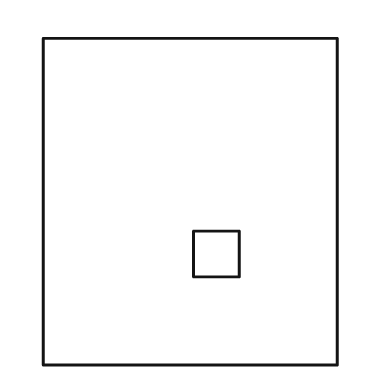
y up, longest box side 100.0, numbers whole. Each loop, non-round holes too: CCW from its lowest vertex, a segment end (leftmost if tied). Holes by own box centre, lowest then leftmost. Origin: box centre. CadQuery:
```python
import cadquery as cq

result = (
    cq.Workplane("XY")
    .moveTo(-45.0, -50.0)
    .lineTo(45.0, -50.0)
    .lineTo(45.0, 50.0)
    .lineTo(-45.0, 50.0)
    .close()
    .moveTo(1.0, -23.0)
    .lineTo(15.0, -23.0)
    .lineTo(15.0, -9.0)
    .lineTo(1.0, -9.0)
    .close()
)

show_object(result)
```